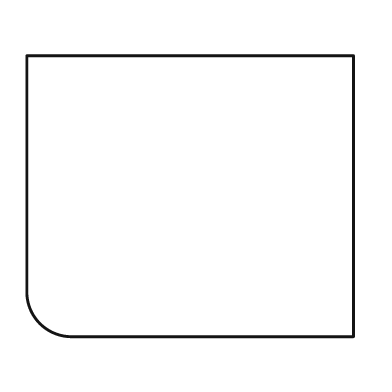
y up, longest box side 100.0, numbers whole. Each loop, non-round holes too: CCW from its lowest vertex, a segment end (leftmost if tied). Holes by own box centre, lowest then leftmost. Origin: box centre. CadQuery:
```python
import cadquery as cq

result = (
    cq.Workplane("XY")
    .moveTo(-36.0, -43.0)
    .lineTo(50.0, -43.0)
    .lineTo(50.0, 43.0)
    .lineTo(-50.0, 43.0)
    .lineTo(-50.0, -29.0)
    .threePointArc((-46.0, -39.0), (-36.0, -43.0))
    .close()
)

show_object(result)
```